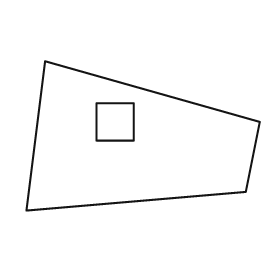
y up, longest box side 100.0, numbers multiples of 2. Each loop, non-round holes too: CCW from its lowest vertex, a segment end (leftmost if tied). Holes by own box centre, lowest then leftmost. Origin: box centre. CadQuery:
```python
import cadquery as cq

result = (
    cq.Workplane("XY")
    .moveTo(-50.0, -32.0)
    .lineTo(44.0, -24.0)
    .lineTo(50.0, 6.0)
    .lineTo(-42.0, 32.0)
    .close()
    .moveTo(-20.0, -2.0)
    .lineTo(-4.0, -2.0)
    .lineTo(-4.0, 14.0)
    .lineTo(-20.0, 14.0)
    .close()
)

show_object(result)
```